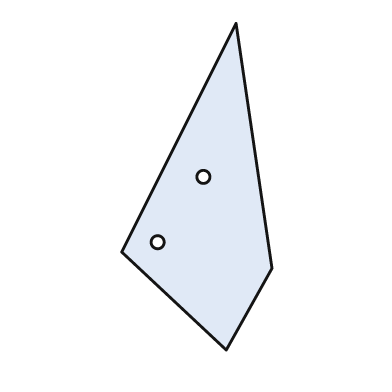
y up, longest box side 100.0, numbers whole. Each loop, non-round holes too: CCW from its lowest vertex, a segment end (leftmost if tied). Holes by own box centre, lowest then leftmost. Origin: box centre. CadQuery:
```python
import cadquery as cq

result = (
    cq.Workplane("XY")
    .moveTo(9.0, -50.0)
    .lineTo(23.0, -25.0)
    .lineTo(12.0, 50.0)
    .lineTo(-23.0, -20.0)
    .close()
    .moveTo(-12.0, -17.0)
    .circle(2.0)
    .moveTo(2.0, 3.0)
    .circle(2.0)
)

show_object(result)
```